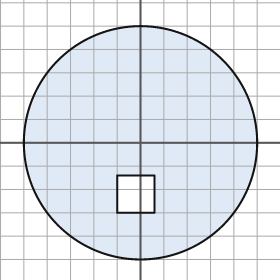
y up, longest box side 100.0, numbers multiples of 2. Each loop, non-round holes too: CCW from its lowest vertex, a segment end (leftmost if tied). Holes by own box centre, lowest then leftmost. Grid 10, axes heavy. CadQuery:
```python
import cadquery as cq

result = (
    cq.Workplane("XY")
    .moveTo(0.0, 0.0)
    .circle(50.0)
    .moveTo(-10.0, -30.0)
    .lineTo(6.0, -30.0)
    .lineTo(6.0, -14.0)
    .lineTo(-10.0, -14.0)
    .close()
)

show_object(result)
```